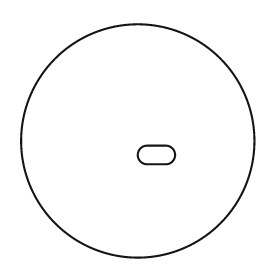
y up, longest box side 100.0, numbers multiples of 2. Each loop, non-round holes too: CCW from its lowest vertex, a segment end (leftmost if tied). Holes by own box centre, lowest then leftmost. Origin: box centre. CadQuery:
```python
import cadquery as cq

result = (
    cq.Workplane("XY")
    .moveTo(0.0, 0.0)
    .circle(50.0)
    .moveTo(4.0, -10.0)
    .lineTo(12.0, -10.0)
    .threePointArc((16.0, -6.0), (12.0, -2.0))
    .lineTo(4.0, -2.0)
    .threePointArc((0.0, -6.0), (4.0, -10.0))
    .close()
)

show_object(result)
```